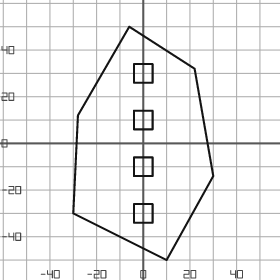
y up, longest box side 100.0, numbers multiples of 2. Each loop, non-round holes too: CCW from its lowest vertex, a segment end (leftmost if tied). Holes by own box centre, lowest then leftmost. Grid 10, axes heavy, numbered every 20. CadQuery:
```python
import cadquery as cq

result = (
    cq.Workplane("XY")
    .moveTo(10.0, -50.0)
    .lineTo(30.0, -14.0)
    .lineTo(22.0, 32.0)
    .lineTo(-6.0, 50.0)
    .lineTo(-28.0, 12.0)
    .lineTo(-30.0, -30.0)
    .close()
    .moveTo(-4.0, -34.0)
    .lineTo(4.0, -34.0)
    .lineTo(4.0, -26.0)
    .lineTo(-4.0, -26.0)
    .close()
    .moveTo(-4.0, -14.0)
    .lineTo(4.0, -14.0)
    .lineTo(4.0, -6.0)
    .lineTo(-4.0, -6.0)
    .close()
    .moveTo(-4.0, 6.0)
    .lineTo(4.0, 6.0)
    .lineTo(4.0, 14.0)
    .lineTo(-4.0, 14.0)
    .close()
    .moveTo(-4.0, 26.0)
    .lineTo(4.0, 26.0)
    .lineTo(4.0, 34.0)
    .lineTo(-4.0, 34.0)
    .close()
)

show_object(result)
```